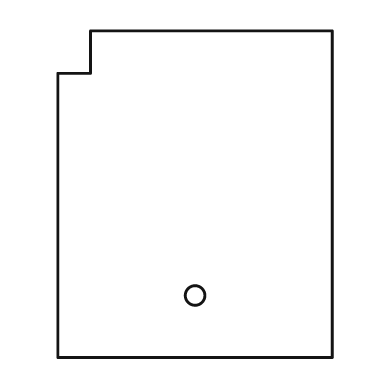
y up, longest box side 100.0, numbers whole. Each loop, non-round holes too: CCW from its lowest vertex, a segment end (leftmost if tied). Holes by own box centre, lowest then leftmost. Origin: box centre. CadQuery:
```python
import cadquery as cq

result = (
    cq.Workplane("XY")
    .moveTo(-42.0, -50.0)
    .lineTo(42.0, -50.0)
    .lineTo(42.0, 50.0)
    .lineTo(-32.0, 50.0)
    .lineTo(-32.0, 37.0)
    .lineTo(-42.0, 37.0)
    .close()
    .moveTo(0.0, -31.0)
    .circle(3.0)
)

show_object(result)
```